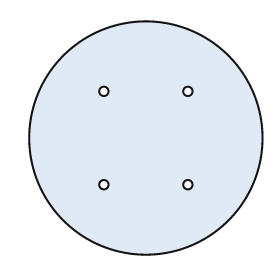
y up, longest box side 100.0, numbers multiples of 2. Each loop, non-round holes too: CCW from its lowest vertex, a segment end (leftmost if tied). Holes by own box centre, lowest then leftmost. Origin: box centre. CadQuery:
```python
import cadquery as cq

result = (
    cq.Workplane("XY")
    .moveTo(0.0, 0.0)
    .circle(50.0)
    .moveTo(-18.0, -20.0)
    .circle(2.0)
    .moveTo(18.0, -20.0)
    .circle(2.0)
    .moveTo(-18.0, 20.0)
    .circle(2.0)
    .moveTo(18.0, 20.0)
    .circle(2.0)
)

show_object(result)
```